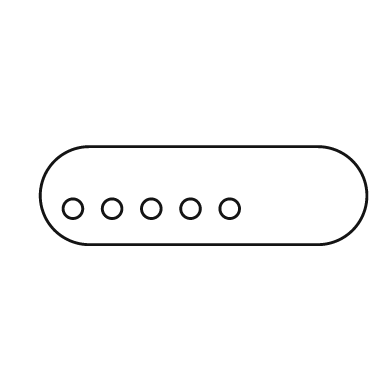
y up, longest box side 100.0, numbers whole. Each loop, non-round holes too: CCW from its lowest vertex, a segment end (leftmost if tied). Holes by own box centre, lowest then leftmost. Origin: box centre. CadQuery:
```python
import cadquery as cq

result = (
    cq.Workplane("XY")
    .moveTo(-35.0, -15.0)
    .lineTo(35.0, -15.0)
    .threePointArc((50.0, 0.0), (35.0, 15.0))
    .lineTo(-35.0, 15.0)
    .threePointArc((-50.0, 0.0), (-35.0, -15.0))
    .close()
    .moveTo(-40.0, -4.0)
    .circle(3.0)
    .moveTo(-28.0, -4.0)
    .circle(3.0)
    .moveTo(-16.0, -4.0)
    .circle(3.0)
    .moveTo(-4.0, -4.0)
    .circle(3.0)
    .moveTo(8.0, -4.0)
    .circle(3.0)
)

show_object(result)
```